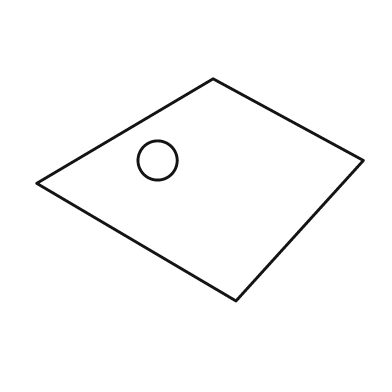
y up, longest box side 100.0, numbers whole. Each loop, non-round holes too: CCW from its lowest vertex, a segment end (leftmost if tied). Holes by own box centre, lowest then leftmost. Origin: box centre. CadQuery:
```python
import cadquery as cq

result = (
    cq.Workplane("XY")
    .moveTo(11.0, -34.0)
    .lineTo(50.0, 9.0)
    .lineTo(4.0, 34.0)
    .lineTo(-50.0, 2.0)
    .close()
    .moveTo(-13.0, 9.0)
    .circle(6.0)
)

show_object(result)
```